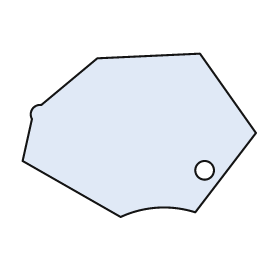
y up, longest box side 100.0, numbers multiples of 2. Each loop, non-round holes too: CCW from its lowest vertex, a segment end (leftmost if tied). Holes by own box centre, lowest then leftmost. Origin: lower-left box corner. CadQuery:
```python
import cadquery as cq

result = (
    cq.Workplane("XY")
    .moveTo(42.0, 0.0)
    .threePointArc((58.0, 4.0), (74.0, 2.0))
    .lineTo(100.0, 36.0)
    .lineTo(76.0, 70.0)
    .lineTo(32.0, 68.0)
    .lineTo(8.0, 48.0)
    .threePointArc((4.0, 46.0), (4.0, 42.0))
    .lineTo(0.0, 24.0)
    .close()
    .moveTo(78.0, 20.0)
    .circle(4.0)
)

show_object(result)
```